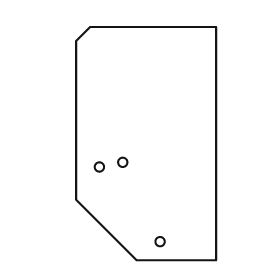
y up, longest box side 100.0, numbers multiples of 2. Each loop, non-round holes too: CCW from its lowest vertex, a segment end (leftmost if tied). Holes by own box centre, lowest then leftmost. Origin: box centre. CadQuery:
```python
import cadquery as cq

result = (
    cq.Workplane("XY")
    .moveTo(-4.0, -50.0)
    .lineTo(30.0, -50.0)
    .lineTo(30.0, 50.0)
    .lineTo(-24.0, 50.0)
    .lineTo(-30.0, 44.0)
    .lineTo(-30.0, -24.0)
    .close()
    .moveTo(6.0, -42.0)
    .circle(2.0)
    .moveTo(-20.0, -10.0)
    .circle(2.0)
    .moveTo(-10.0, -8.0)
    .circle(2.0)
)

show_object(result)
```